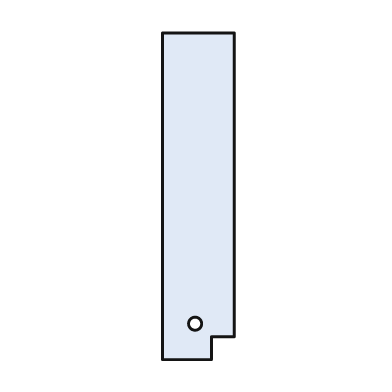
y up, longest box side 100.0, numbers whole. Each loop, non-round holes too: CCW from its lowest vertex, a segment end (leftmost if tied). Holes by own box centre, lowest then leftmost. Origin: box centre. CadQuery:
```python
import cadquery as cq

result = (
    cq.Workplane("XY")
    .moveTo(-11.0, -50.0)
    .lineTo(4.0, -50.0)
    .lineTo(4.0, -43.0)
    .lineTo(11.0, -43.0)
    .lineTo(11.0, 50.0)
    .lineTo(-11.0, 50.0)
    .close()
    .moveTo(-1.0, -39.0)
    .circle(2.0)
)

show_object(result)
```